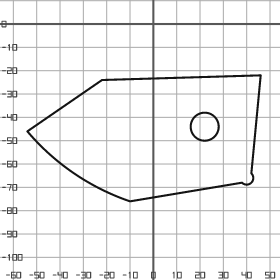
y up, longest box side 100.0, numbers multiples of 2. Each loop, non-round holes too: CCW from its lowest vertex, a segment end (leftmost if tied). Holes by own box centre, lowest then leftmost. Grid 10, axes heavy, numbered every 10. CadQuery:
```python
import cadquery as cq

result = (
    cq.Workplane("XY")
    .moveTo(-10.0, -76.0)
    .lineTo(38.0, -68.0)
    .threePointArc((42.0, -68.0), (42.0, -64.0))
    .lineTo(46.0, -22.0)
    .lineTo(-22.0, -24.0)
    .lineTo(-54.0, -46.0)
    .threePointArc((-34.0, -64.0), (-10.0, -76.0))
    .close()
    .moveTo(22.0, -44.0)
    .circle(6.0)
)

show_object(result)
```